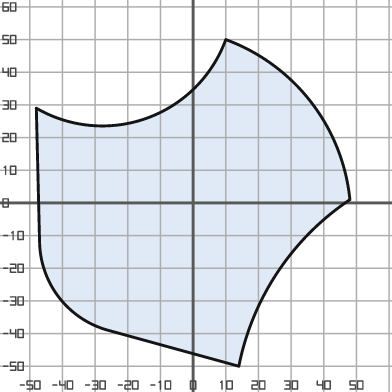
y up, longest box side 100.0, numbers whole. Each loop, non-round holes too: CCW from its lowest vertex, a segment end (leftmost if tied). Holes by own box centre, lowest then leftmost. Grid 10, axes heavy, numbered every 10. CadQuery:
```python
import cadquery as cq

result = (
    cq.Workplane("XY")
    .moveTo(14.0, -50.0)
    .threePointArc((26.0, -21.0), (48.0, 1.0))
    .threePointArc((36.0, 31.0), (10.0, 50.0))
    .threePointArc((-14.0, 26.0), (-48.0, 29.0))
    .lineTo(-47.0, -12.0)
    .threePointArc((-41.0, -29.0), (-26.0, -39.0))
    .close()
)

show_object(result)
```